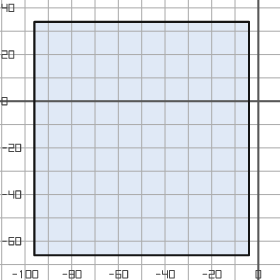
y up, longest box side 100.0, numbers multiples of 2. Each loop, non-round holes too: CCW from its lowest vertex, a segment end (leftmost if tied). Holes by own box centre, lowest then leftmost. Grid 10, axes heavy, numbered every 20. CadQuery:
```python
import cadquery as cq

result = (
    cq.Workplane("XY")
    .moveTo(-96.0, -66.0)
    .lineTo(-4.0, -66.0)
    .lineTo(-4.0, 34.0)
    .lineTo(-96.0, 34.0)
    .close()
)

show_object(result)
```